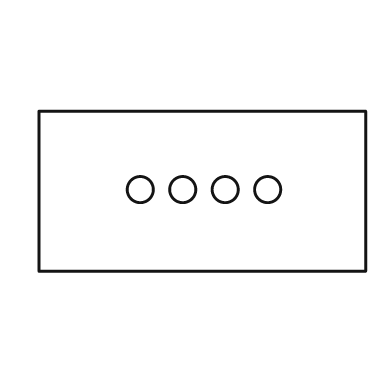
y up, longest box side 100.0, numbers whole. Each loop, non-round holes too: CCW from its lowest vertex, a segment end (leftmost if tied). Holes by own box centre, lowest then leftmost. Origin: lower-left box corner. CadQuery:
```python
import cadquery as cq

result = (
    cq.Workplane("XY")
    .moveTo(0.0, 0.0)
    .lineTo(100.0, 0.0)
    .lineTo(100.0, 49.0)
    .lineTo(0.0, 49.0)
    .close()
    .moveTo(31.0, 25.0)
    .circle(4.0)
    .moveTo(44.0, 25.0)
    .circle(4.0)
    .moveTo(57.0, 25.0)
    .circle(4.0)
    .moveTo(70.0, 25.0)
    .circle(4.0)
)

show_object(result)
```